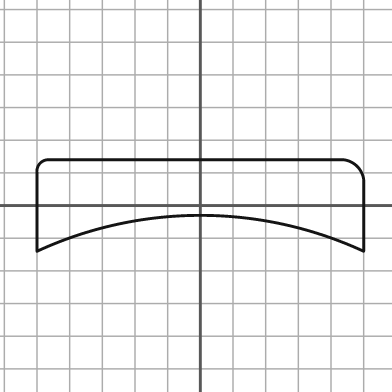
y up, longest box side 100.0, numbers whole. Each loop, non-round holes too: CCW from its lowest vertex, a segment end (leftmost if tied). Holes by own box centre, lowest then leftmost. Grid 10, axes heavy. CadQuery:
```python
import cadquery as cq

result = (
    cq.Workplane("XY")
    .moveTo(-50.0, -14.0)
    .threePointArc((0.0, -3.0), (50.0, -14.0))
    .lineTo(50.0, 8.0)
    .threePointArc((48.0, 12.0), (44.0, 14.0))
    .lineTo(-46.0, 14.0)
    .threePointArc((-49.0, 13.0), (-50.0, 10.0))
    .close()
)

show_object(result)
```